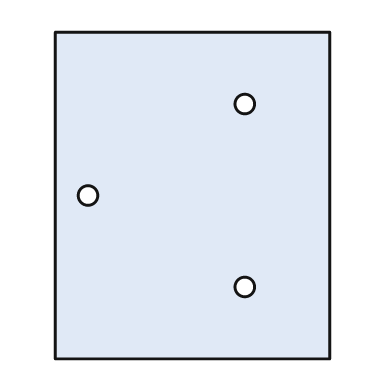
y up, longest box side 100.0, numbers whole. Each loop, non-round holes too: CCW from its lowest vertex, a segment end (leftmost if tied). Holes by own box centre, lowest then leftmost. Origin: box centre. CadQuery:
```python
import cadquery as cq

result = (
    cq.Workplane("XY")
    .moveTo(-42.0, -50.0)
    .lineTo(42.0, -50.0)
    .lineTo(42.0, 50.0)
    .lineTo(-42.0, 50.0)
    .close()
    .moveTo(16.0, -28.0)
    .circle(3.0)
    .moveTo(-32.0, 0.0)
    .circle(3.0)
    .moveTo(16.0, 28.0)
    .circle(3.0)
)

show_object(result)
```